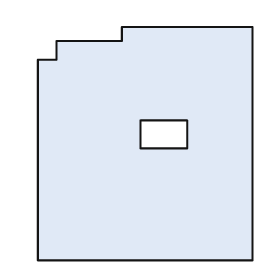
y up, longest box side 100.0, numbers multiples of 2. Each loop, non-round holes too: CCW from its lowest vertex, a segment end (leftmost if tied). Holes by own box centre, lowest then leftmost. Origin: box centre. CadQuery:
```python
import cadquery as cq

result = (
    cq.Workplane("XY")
    .moveTo(-46.0, -50.0)
    .lineTo(46.0, -50.0)
    .lineTo(46.0, 50.0)
    .lineTo(-10.0, 50.0)
    .lineTo(-10.0, 44.0)
    .lineTo(-38.0, 44.0)
    .lineTo(-38.0, 36.0)
    .lineTo(-46.0, 36.0)
    .close()
    .moveTo(-2.0, -2.0)
    .lineTo(18.0, -2.0)
    .lineTo(18.0, 10.0)
    .lineTo(-2.0, 10.0)
    .close()
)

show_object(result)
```